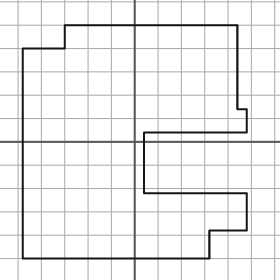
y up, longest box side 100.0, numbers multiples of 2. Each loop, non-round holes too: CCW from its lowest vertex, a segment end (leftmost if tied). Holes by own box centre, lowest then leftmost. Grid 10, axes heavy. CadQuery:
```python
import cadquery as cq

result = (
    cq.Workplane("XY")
    .moveTo(-48.0, -50.0)
    .lineTo(32.0, -50.0)
    .lineTo(32.0, -38.0)
    .lineTo(48.0, -38.0)
    .lineTo(48.0, -22.0)
    .lineTo(4.0, -22.0)
    .lineTo(4.0, 4.0)
    .lineTo(48.0, 4.0)
    .lineTo(48.0, 14.0)
    .lineTo(44.0, 14.0)
    .lineTo(44.0, 50.0)
    .lineTo(-30.0, 50.0)
    .lineTo(-30.0, 40.0)
    .lineTo(-48.0, 40.0)
    .close()
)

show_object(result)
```